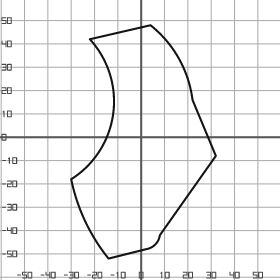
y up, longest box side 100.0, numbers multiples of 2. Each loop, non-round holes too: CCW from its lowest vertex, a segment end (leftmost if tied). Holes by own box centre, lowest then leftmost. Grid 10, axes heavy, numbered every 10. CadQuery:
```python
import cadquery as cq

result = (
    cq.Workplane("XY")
    .moveTo(-14.0, -52.0)
    .lineTo(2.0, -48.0)
    .threePointArc((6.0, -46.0), (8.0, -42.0))
    .lineTo(32.0, -8.0)
    .lineTo(22.0, 16.0)
    .threePointArc((16.0, 34.0), (4.0, 48.0))
    .lineTo(-22.0, 42.0)
    .threePointArc((-12.0, 10.0), (-30.0, -18.0))
    .threePointArc((-24.0, -36.0), (-14.0, -52.0))
    .close()
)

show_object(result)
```